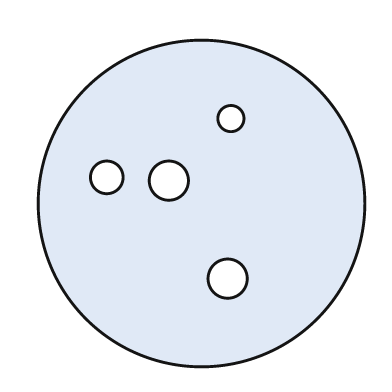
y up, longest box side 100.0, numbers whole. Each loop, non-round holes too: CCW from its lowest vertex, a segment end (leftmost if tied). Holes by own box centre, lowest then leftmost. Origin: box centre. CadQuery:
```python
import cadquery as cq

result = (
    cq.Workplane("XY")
    .moveTo(0.0, 0.0)
    .circle(50.0)
    .moveTo(8.0, -23.0)
    .circle(6.0)
    .moveTo(-10.0, 7.0)
    .circle(6.0)
    .moveTo(-29.0, 8.0)
    .circle(5.0)
    .moveTo(9.0, 26.0)
    .circle(4.0)
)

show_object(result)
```